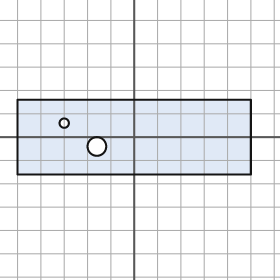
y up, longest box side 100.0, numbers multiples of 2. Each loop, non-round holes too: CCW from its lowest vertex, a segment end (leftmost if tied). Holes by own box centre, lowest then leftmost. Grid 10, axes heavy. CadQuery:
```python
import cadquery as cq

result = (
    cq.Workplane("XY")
    .moveTo(-50.0, -16.0)
    .lineTo(50.0, -16.0)
    .lineTo(50.0, 16.0)
    .lineTo(-50.0, 16.0)
    .close()
    .moveTo(-16.0, -4.0)
    .circle(4.0)
    .moveTo(-30.0, 6.0)
    .circle(2.0)
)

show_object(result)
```